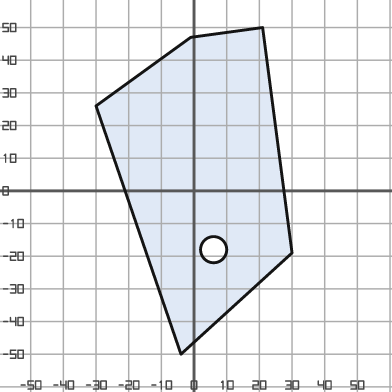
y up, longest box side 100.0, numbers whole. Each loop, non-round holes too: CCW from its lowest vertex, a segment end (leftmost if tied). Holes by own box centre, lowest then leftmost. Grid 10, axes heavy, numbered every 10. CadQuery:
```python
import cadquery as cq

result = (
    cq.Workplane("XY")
    .moveTo(-4.0, -50.0)
    .lineTo(30.0, -19.0)
    .lineTo(21.0, 50.0)
    .lineTo(-1.0, 47.0)
    .lineTo(-30.0, 26.0)
    .close()
    .moveTo(6.0, -18.0)
    .circle(4.0)
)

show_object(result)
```